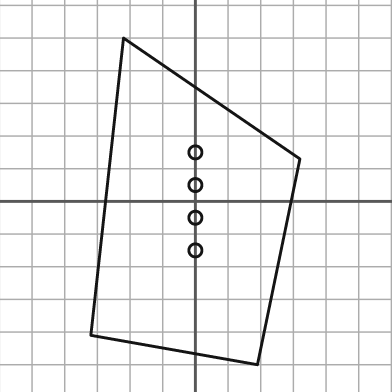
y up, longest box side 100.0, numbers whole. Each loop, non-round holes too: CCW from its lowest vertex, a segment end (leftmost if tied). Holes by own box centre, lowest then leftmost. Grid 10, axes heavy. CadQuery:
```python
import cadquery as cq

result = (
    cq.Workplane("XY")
    .moveTo(19.0, -50.0)
    .lineTo(32.0, 13.0)
    .lineTo(-22.0, 50.0)
    .lineTo(-32.0, -41.0)
    .close()
    .moveTo(0.0, -15.0)
    .circle(2.0)
    .moveTo(0.0, -5.0)
    .circle(2.0)
    .moveTo(0.0, 5.0)
    .circle(2.0)
    .moveTo(0.0, 15.0)
    .circle(2.0)
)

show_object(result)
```